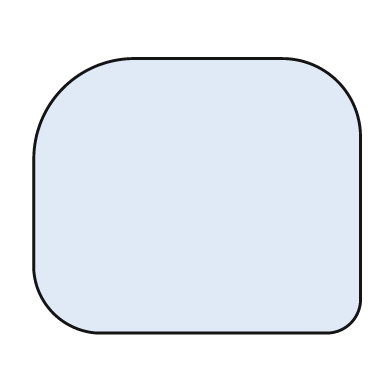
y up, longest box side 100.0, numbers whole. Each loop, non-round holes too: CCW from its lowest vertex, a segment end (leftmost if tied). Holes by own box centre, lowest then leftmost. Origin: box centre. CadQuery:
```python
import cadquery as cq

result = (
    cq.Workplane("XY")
    .moveTo(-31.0, -42.0)
    .lineTo(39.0, -42.0)
    .threePointArc((47.0, -39.0), (50.0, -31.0))
    .lineTo(50.0, 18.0)
    .threePointArc((43.0, 35.0), (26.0, 42.0))
    .lineTo(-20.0, 42.0)
    .threePointArc((-41.0, 33.0), (-50.0, 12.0))
    .lineTo(-50.0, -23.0)
    .threePointArc((-44.0, -36.0), (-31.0, -42.0))
    .close()
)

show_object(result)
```